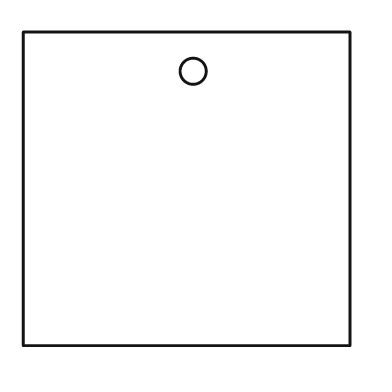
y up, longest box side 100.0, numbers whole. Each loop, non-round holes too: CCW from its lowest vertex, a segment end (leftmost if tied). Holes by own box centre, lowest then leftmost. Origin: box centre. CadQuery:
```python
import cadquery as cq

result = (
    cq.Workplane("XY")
    .moveTo(-50.0, -48.0)
    .lineTo(50.0, -48.0)
    .lineTo(50.0, 48.0)
    .lineTo(-50.0, 48.0)
    .close()
    .moveTo(2.0, 36.0)
    .circle(4.0)
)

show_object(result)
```